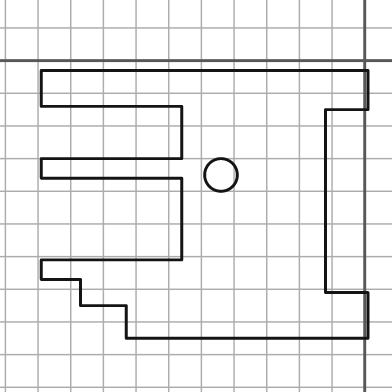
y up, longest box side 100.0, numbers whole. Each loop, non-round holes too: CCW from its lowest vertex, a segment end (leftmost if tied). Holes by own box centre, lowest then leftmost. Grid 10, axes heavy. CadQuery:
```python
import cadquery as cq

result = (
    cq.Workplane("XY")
    .moveTo(-73.0, -85.0)
    .lineTo(1.0, -85.0)
    .lineTo(1.0, -71.0)
    .lineTo(-12.0, -71.0)
    .lineTo(-12.0, -15.0)
    .lineTo(1.0, -15.0)
    .lineTo(1.0, -3.0)
    .lineTo(-99.0, -3.0)
    .lineTo(-99.0, -14.0)
    .lineTo(-56.0, -14.0)
    .lineTo(-56.0, -30.0)
    .lineTo(-99.0, -30.0)
    .lineTo(-99.0, -36.0)
    .lineTo(-56.0, -36.0)
    .lineTo(-56.0, -61.0)
    .lineTo(-99.0, -61.0)
    .lineTo(-99.0, -67.0)
    .lineTo(-87.0, -67.0)
    .lineTo(-87.0, -75.0)
    .lineTo(-73.0, -75.0)
    .close()
    .moveTo(-44.0, -35.0)
    .circle(5.0)
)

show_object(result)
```